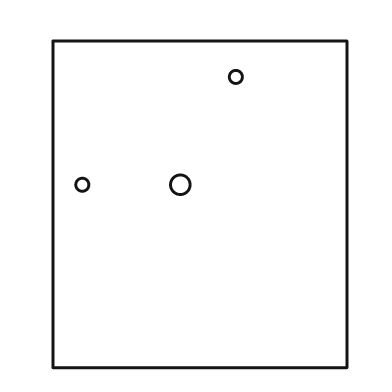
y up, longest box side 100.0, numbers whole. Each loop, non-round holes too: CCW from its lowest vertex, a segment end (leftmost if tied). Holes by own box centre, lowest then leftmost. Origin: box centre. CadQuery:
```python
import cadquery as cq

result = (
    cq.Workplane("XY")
    .moveTo(-45.0, -50.0)
    .lineTo(45.0, -50.0)
    .lineTo(45.0, 50.0)
    .lineTo(-45.0, 50.0)
    .close()
    .moveTo(-36.0, 6.0)
    .circle(2.0)
    .moveTo(-6.0, 6.0)
    .circle(3.0)
    .moveTo(11.0, 39.0)
    .circle(2.0)
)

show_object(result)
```